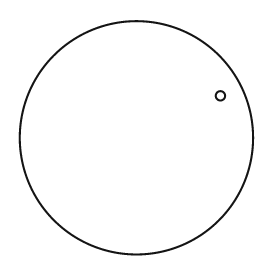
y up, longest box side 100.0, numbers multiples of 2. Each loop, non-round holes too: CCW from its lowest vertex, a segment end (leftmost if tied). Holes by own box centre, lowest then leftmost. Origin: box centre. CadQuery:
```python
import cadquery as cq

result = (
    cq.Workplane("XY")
    .moveTo(0.0, 0.0)
    .circle(50.0)
    .moveTo(36.0, 18.0)
    .circle(2.0)
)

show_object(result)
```